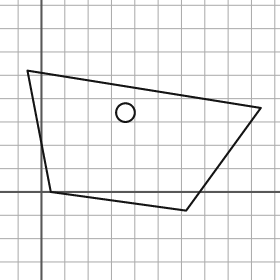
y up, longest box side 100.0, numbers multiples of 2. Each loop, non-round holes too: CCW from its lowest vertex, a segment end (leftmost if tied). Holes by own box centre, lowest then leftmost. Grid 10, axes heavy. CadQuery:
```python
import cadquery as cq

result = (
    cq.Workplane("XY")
    .moveTo(62.0, -8.0)
    .lineTo(94.0, 36.0)
    .lineTo(-6.0, 52.0)
    .lineTo(4.0, 0.0)
    .close()
    .moveTo(36.0, 34.0)
    .circle(4.0)
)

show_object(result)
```